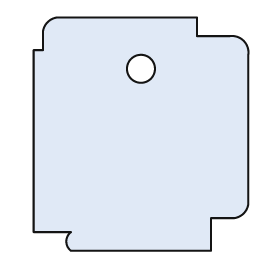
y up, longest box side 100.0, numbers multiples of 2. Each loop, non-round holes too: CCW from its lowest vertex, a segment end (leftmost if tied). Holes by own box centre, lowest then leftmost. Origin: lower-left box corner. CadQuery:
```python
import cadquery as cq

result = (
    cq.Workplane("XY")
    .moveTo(16.0, 0.0)
    .lineTo(76.0, 0.0)
    .lineTo(76.0, 14.0)
    .lineTo(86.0, 14.0)
    .threePointArc((90.0, 16.0), (92.0, 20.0))
    .lineTo(92.0, 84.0)
    .threePointArc((90.0, 90.0), (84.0, 92.0))
    .lineTo(70.0, 92.0)
    .lineTo(70.0, 100.0)
    .lineTo(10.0, 100.0)
    .threePointArc((6.0, 98.0), (4.0, 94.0))
    .lineTo(4.0, 86.0)
    .lineTo(0.0, 86.0)
    .lineTo(0.0, 8.0)
    .lineTo(16.0, 8.0)
    .threePointArc((14.0, 4.0), (16.0, 0.0))
    .close()
    .moveTo(46.0, 78.0)
    .circle(6.0)
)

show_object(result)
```